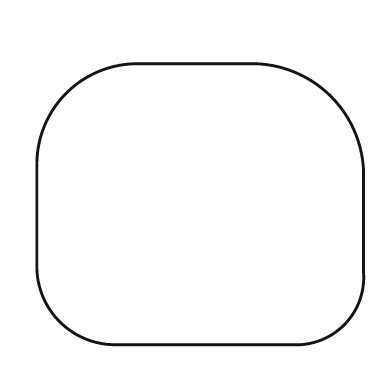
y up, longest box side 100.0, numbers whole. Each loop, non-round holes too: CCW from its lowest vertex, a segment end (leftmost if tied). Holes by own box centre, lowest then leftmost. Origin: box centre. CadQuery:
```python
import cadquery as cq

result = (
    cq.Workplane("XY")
    .moveTo(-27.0, -43.0)
    .lineTo(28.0, -43.0)
    .threePointArc((44.0, -37.0), (50.0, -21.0))
    .lineTo(50.0, 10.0)
    .threePointArc((40.0, 33.0), (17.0, 43.0))
    .lineTo(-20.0, 43.0)
    .threePointArc((-41.0, 34.0), (-50.0, 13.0))
    .lineTo(-50.0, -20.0)
    .threePointArc((-43.0, -36.0), (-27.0, -43.0))
    .close()
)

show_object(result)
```